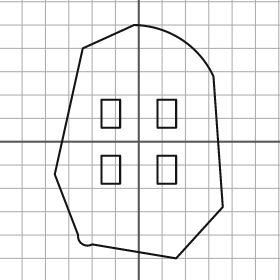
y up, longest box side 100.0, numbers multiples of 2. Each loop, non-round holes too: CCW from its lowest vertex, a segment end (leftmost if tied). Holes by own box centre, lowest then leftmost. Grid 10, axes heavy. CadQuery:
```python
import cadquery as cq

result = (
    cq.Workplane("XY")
    .moveTo(16.0, -50.0)
    .lineTo(36.0, -28.0)
    .lineTo(32.0, 28.0)
    .threePointArc((18.0, 44.0), (-2.0, 50.0))
    .lineTo(-24.0, 40.0)
    .lineTo(-36.0, -14.0)
    .lineTo(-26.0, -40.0)
    .threePointArc((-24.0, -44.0), (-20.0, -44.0))
    .close()
    .moveTo(-16.0, -18.0)
    .lineTo(-8.0, -18.0)
    .lineTo(-8.0, -6.0)
    .lineTo(-16.0, -6.0)
    .close()
    .moveTo(8.0, -18.0)
    .lineTo(16.0, -18.0)
    .lineTo(16.0, -6.0)
    .lineTo(8.0, -6.0)
    .close()
    .moveTo(-16.0, 6.0)
    .lineTo(-8.0, 6.0)
    .lineTo(-8.0, 18.0)
    .lineTo(-16.0, 18.0)
    .close()
    .moveTo(8.0, 6.0)
    .lineTo(16.0, 6.0)
    .lineTo(16.0, 18.0)
    .lineTo(8.0, 18.0)
    .close()
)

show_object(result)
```